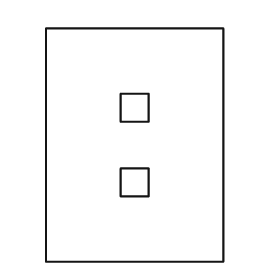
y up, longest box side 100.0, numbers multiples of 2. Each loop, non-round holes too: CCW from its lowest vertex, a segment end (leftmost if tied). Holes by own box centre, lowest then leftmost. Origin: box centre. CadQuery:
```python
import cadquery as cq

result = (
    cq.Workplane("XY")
    .moveTo(-38.0, -50.0)
    .lineTo(38.0, -50.0)
    .lineTo(38.0, 50.0)
    .lineTo(-38.0, 50.0)
    .close()
    .moveTo(-6.0, -22.0)
    .lineTo(6.0, -22.0)
    .lineTo(6.0, -10.0)
    .lineTo(-6.0, -10.0)
    .close()
    .moveTo(-6.0, 10.0)
    .lineTo(6.0, 10.0)
    .lineTo(6.0, 22.0)
    .lineTo(-6.0, 22.0)
    .close()
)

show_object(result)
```